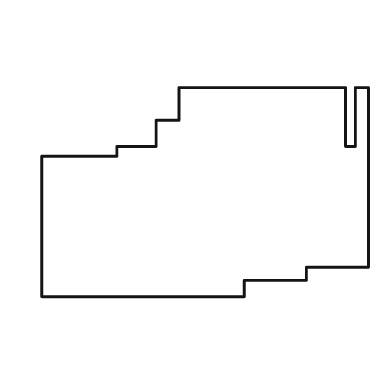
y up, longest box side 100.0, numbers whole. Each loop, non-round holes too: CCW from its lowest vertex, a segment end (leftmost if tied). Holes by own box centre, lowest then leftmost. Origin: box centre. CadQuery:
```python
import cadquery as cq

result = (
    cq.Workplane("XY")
    .moveTo(-50.0, -32.0)
    .lineTo(12.0, -32.0)
    .lineTo(12.0, -27.0)
    .lineTo(31.0, -27.0)
    .lineTo(31.0, -23.0)
    .lineTo(50.0, -23.0)
    .lineTo(50.0, 32.0)
    .lineTo(46.0, 32.0)
    .lineTo(46.0, 14.0)
    .lineTo(43.0, 14.0)
    .lineTo(43.0, 32.0)
    .lineTo(-8.0, 32.0)
    .lineTo(-8.0, 22.0)
    .lineTo(-15.0, 22.0)
    .lineTo(-15.0, 14.0)
    .lineTo(-27.0, 14.0)
    .lineTo(-27.0, 11.0)
    .lineTo(-50.0, 11.0)
    .close()
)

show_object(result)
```